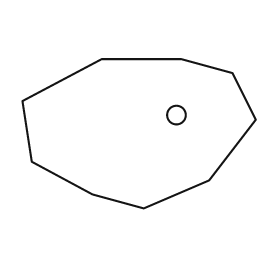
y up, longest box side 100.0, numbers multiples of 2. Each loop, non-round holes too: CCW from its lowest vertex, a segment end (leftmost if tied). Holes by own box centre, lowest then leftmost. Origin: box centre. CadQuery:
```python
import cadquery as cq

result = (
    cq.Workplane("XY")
    .moveTo(2.0, -32.0)
    .lineTo(30.0, -20.0)
    .lineTo(50.0, 6.0)
    .lineTo(40.0, 26.0)
    .lineTo(18.0, 32.0)
    .lineTo(-16.0, 32.0)
    .lineTo(-50.0, 14.0)
    .lineTo(-46.0, -12.0)
    .lineTo(-20.0, -26.0)
    .close()
    .moveTo(16.0, 8.0)
    .circle(4.0)
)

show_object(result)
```